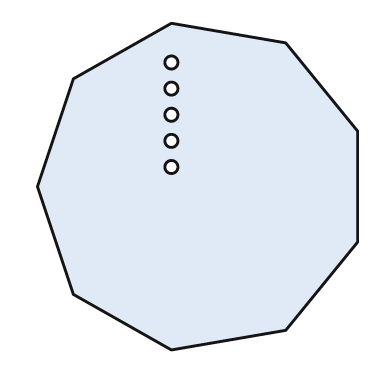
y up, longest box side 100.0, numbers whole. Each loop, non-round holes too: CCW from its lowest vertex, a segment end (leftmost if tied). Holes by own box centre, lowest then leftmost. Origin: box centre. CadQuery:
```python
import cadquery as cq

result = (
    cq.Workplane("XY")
    .moveTo(-8.0, -50.0)
    .lineTo(27.0, -44.0)
    .lineTo(49.0, -17.0)
    .lineTo(49.0, 17.0)
    .lineTo(27.0, 44.0)
    .lineTo(-8.0, 50.0)
    .lineTo(-38.0, 33.0)
    .lineTo(-49.0, 0.0)
    .lineTo(-38.0, -33.0)
    .close()
    .moveTo(-8.0, 6.0)
    .circle(2.0)
    .moveTo(-8.0, 14.0)
    .circle(2.0)
    .moveTo(-8.0, 22.0)
    .circle(2.0)
    .moveTo(-8.0, 30.0)
    .circle(2.0)
    .moveTo(-8.0, 38.0)
    .circle(2.0)
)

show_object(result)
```